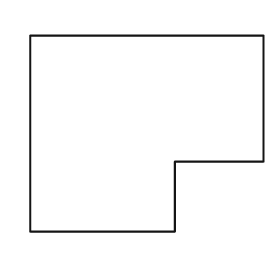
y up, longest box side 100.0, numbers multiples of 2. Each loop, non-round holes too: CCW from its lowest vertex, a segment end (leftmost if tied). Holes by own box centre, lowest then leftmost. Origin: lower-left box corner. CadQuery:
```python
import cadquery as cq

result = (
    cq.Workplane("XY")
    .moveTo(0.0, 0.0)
    .lineTo(62.0, 0.0)
    .lineTo(62.0, 30.0)
    .lineTo(100.0, 30.0)
    .lineTo(100.0, 84.0)
    .lineTo(0.0, 84.0)
    .close()
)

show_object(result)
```